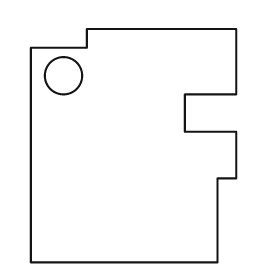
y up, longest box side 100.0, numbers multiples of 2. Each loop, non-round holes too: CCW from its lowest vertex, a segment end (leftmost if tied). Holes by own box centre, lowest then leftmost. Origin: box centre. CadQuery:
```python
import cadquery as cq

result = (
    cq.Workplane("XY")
    .moveTo(-44.0, -50.0)
    .lineTo(36.0, -50.0)
    .lineTo(36.0, -14.0)
    .lineTo(44.0, -14.0)
    .lineTo(44.0, 6.0)
    .lineTo(22.0, 6.0)
    .lineTo(22.0, 22.0)
    .lineTo(44.0, 22.0)
    .lineTo(44.0, 50.0)
    .lineTo(-20.0, 50.0)
    .lineTo(-20.0, 42.0)
    .lineTo(-44.0, 42.0)
    .close()
    .moveTo(-30.0, 30.0)
    .circle(8.0)
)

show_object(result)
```